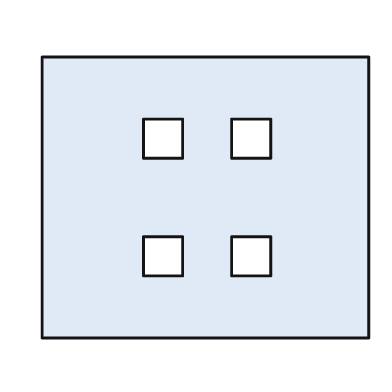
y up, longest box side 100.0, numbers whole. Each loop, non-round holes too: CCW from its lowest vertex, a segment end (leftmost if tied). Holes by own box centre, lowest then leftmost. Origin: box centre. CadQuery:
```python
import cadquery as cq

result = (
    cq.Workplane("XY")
    .moveTo(-50.0, -43.0)
    .lineTo(50.0, -43.0)
    .lineTo(50.0, 43.0)
    .lineTo(-50.0, 43.0)
    .close()
    .moveTo(-19.0, -24.0)
    .lineTo(-7.0, -24.0)
    .lineTo(-7.0, -12.0)
    .lineTo(-19.0, -12.0)
    .close()
    .moveTo(8.0, -24.0)
    .lineTo(20.0, -24.0)
    .lineTo(20.0, -12.0)
    .lineTo(8.0, -12.0)
    .close()
    .moveTo(-19.0, 12.0)
    .lineTo(-7.0, 12.0)
    .lineTo(-7.0, 24.0)
    .lineTo(-19.0, 24.0)
    .close()
    .moveTo(8.0, 12.0)
    .lineTo(20.0, 12.0)
    .lineTo(20.0, 24.0)
    .lineTo(8.0, 24.0)
    .close()
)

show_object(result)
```